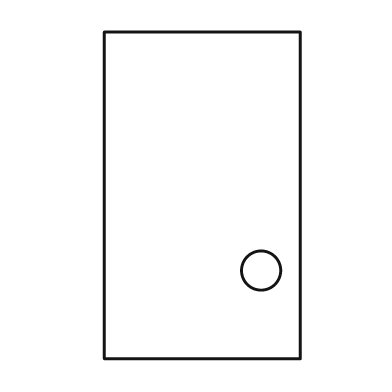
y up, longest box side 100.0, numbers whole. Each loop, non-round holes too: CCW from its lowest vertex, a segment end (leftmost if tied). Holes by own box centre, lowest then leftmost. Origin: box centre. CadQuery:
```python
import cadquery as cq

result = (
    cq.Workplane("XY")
    .moveTo(-30.0, -50.0)
    .lineTo(30.0, -50.0)
    .lineTo(30.0, 50.0)
    .lineTo(-30.0, 50.0)
    .close()
    .moveTo(18.0, -23.0)
    .circle(6.0)
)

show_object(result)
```